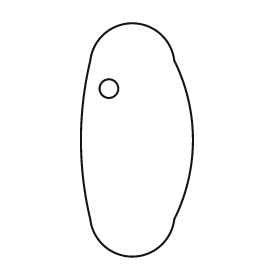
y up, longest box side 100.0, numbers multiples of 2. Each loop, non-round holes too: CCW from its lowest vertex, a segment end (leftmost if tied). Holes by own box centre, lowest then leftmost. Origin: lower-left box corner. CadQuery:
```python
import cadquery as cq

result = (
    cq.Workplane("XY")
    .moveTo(4.0, 16.0)
    .threePointArc((22.0, 0.0), (40.0, 16.0))
    .threePointArc((48.0, 50.0), (40.0, 84.0))
    .threePointArc((22.0, 100.0), (4.0, 84.0))
    .threePointArc((0.0, 50.0), (4.0, 16.0))
    .close()
    .moveTo(12.0, 72.0)
    .circle(4.0)
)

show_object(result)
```